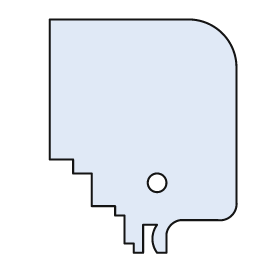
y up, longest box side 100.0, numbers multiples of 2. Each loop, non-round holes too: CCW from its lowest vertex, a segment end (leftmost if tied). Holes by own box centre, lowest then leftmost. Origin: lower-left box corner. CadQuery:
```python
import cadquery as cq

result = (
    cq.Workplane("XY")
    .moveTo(36.0, 0.0)
    .lineTo(40.0, 0.0)
    .lineTo(40.0, 12.0)
    .lineTo(46.0, 12.0)
    .threePointArc((44.0, 6.0), (46.0, 0.0))
    .lineTo(50.0, 0.0)
    .lineTo(50.0, 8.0)
    .threePointArc((52.0, 12.0), (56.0, 14.0))
    .lineTo(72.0, 14.0)
    .threePointArc((78.0, 16.0), (80.0, 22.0))
    .lineTo(80.0, 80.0)
    .threePointArc((74.0, 94.0), (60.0, 100.0))
    .lineTo(0.0, 100.0)
    .lineTo(0.0, 40.0)
    .lineTo(10.0, 40.0)
    .lineTo(10.0, 34.0)
    .lineTo(18.0, 34.0)
    .lineTo(18.0, 20.0)
    .lineTo(28.0, 20.0)
    .lineTo(28.0, 16.0)
    .lineTo(32.0, 16.0)
    .lineTo(32.0, 4.0)
    .lineTo(36.0, 4.0)
    .close()
    .moveTo(46.0, 30.0)
    .circle(4.0)
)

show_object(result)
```